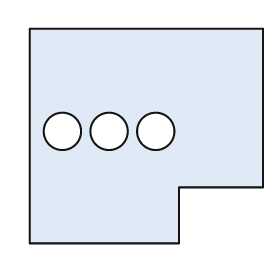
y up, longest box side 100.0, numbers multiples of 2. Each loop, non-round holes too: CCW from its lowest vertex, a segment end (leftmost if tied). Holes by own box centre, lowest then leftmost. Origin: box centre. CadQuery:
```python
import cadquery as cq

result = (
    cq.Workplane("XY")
    .moveTo(-50.0, -46.0)
    .lineTo(14.0, -46.0)
    .lineTo(14.0, -22.0)
    .lineTo(50.0, -22.0)
    .lineTo(50.0, 46.0)
    .lineTo(-50.0, 46.0)
    .close()
    .moveTo(-36.0, 2.0)
    .circle(8.0)
    .moveTo(-16.0, 2.0)
    .circle(8.0)
    .moveTo(4.0, 2.0)
    .circle(8.0)
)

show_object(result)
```